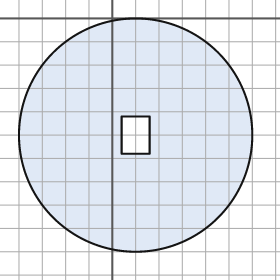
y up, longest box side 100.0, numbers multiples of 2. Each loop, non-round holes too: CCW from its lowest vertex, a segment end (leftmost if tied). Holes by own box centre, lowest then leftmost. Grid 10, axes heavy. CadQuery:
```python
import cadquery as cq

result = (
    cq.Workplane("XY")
    .moveTo(10.0, -50.0)
    .circle(50.0)
    .moveTo(4.0, -58.0)
    .lineTo(16.0, -58.0)
    .lineTo(16.0, -42.0)
    .lineTo(4.0, -42.0)
    .close()
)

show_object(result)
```